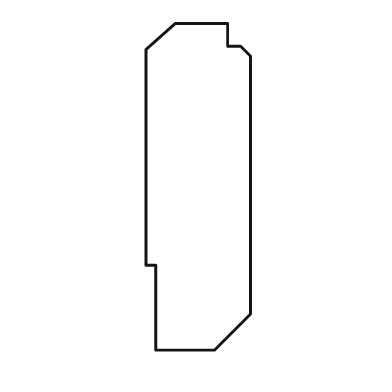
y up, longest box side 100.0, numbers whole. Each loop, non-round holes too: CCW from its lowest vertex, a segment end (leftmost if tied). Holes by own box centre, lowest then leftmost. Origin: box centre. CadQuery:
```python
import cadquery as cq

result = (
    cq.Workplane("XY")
    .moveTo(-13.0, -50.0)
    .lineTo(5.0, -50.0)
    .lineTo(16.0, -39.0)
    .lineTo(16.0, 40.0)
    .lineTo(13.0, 43.0)
    .lineTo(9.0, 43.0)
    .lineTo(9.0, 50.0)
    .lineTo(-7.0, 50.0)
    .lineTo(-16.0, 42.0)
    .lineTo(-16.0, -24.0)
    .lineTo(-13.0, -24.0)
    .close()
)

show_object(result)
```